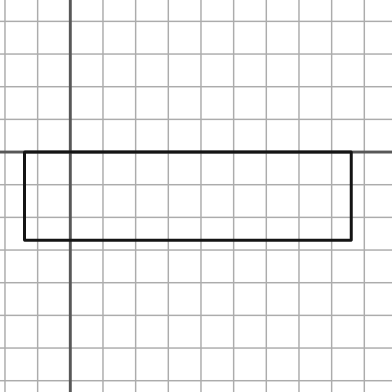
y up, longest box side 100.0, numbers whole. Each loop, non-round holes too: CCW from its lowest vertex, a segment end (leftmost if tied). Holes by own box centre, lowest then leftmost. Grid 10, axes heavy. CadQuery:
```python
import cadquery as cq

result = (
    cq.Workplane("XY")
    .moveTo(-14.0, -27.0)
    .lineTo(86.0, -27.0)
    .lineTo(86.0, 0.0)
    .lineTo(-14.0, 0.0)
    .close()
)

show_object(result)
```